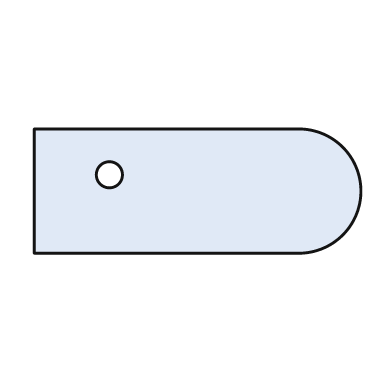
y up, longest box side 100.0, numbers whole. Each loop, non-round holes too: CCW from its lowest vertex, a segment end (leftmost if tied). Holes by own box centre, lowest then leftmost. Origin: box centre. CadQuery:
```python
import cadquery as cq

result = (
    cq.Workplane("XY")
    .moveTo(-50.0, -19.0)
    .lineTo(32.0, -19.0)
    .threePointArc((50.0, 0.0), (32.0, 19.0))
    .lineTo(-50.0, 19.0)
    .close()
    .moveTo(-27.0, 5.0)
    .circle(4.0)
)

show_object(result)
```